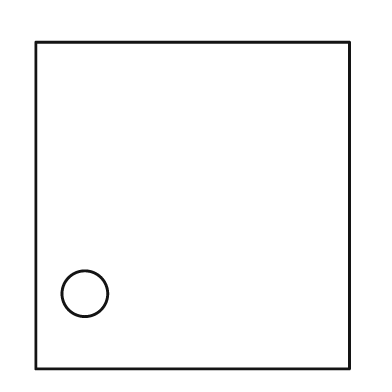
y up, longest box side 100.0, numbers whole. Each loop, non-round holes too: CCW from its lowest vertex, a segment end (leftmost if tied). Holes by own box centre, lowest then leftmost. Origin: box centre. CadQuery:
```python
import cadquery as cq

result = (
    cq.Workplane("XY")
    .moveTo(-48.0, -50.0)
    .lineTo(48.0, -50.0)
    .lineTo(48.0, 50.0)
    .lineTo(-48.0, 50.0)
    .close()
    .moveTo(-33.0, -27.0)
    .circle(7.0)
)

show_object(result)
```